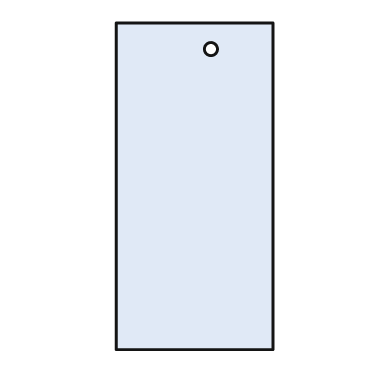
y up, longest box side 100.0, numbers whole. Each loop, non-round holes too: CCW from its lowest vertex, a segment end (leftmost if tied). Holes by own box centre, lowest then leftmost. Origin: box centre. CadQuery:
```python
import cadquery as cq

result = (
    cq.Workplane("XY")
    .moveTo(-24.0, -50.0)
    .lineTo(24.0, -50.0)
    .lineTo(24.0, 50.0)
    .lineTo(-24.0, 50.0)
    .close()
    .moveTo(5.0, 42.0)
    .circle(2.0)
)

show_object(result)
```